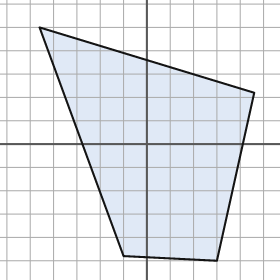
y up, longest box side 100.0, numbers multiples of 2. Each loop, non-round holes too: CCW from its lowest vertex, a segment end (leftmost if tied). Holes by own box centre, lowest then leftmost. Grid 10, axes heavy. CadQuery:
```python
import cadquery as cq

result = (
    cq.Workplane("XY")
    .moveTo(30.0, -50.0)
    .lineTo(46.0, 22.0)
    .lineTo(-46.0, 50.0)
    .lineTo(-10.0, -48.0)
    .close()
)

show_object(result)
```